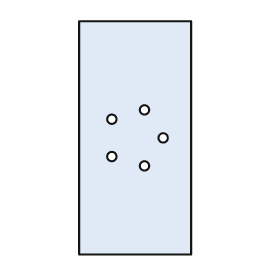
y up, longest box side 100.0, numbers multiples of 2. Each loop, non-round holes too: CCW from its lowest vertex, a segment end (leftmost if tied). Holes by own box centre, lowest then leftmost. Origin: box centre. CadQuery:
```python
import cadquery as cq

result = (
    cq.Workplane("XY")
    .moveTo(-24.0, -50.0)
    .lineTo(24.0, -50.0)
    .lineTo(24.0, 50.0)
    .lineTo(-24.0, 50.0)
    .close()
    .moveTo(4.0, -12.0)
    .circle(2.0)
    .moveTo(-10.0, -8.0)
    .circle(2.0)
    .moveTo(12.0, 0.0)
    .circle(2.0)
    .moveTo(-10.0, 8.0)
    .circle(2.0)
    .moveTo(4.0, 12.0)
    .circle(2.0)
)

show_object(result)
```